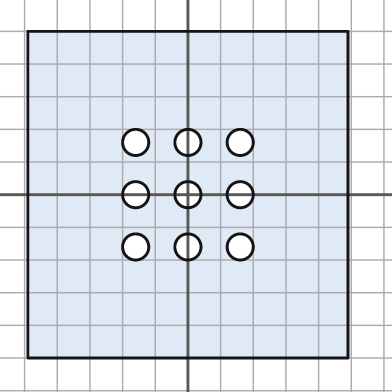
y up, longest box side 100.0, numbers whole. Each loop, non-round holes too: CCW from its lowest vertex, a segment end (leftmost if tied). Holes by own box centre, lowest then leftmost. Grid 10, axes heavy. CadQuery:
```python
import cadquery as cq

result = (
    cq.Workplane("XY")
    .moveTo(-49.0, -50.0)
    .lineTo(49.0, -50.0)
    .lineTo(49.0, 50.0)
    .lineTo(-49.0, 50.0)
    .close()
    .moveTo(-16.0, -16.0)
    .circle(4.0)
    .moveTo(0.0, -16.0)
    .circle(4.0)
    .moveTo(16.0, -16.0)
    .circle(4.0)
    .moveTo(-16.0, 0.0)
    .circle(4.0)
    .moveTo(0.0, 0.0)
    .circle(4.0)
    .moveTo(16.0, 0.0)
    .circle(4.0)
    .moveTo(-16.0, 16.0)
    .circle(4.0)
    .moveTo(0.0, 16.0)
    .circle(4.0)
    .moveTo(16.0, 16.0)
    .circle(4.0)
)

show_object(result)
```